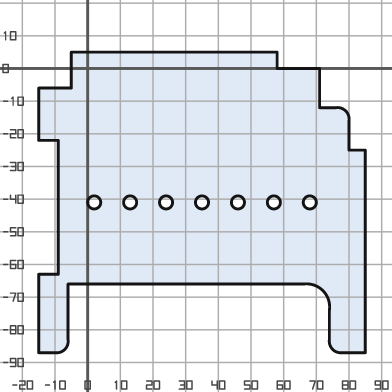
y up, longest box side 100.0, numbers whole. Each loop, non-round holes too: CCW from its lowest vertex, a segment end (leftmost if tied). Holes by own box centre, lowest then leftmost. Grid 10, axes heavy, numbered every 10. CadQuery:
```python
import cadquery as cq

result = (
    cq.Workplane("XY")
    .moveTo(-15.0, -87.0)
    .lineTo(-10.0, -87.0)
    .threePointArc((-7.0, -86.0), (-6.0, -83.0))
    .lineTo(-6.0, -66.0)
    .lineTo(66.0, -66.0)
    .threePointArc((72.0, -68.0), (74.0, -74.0))
    .lineTo(74.0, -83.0)
    .threePointArc((75.0, -86.0), (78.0, -87.0))
    .lineTo(85.0, -87.0)
    .lineTo(85.0, -25.0)
    .lineTo(80.0, -25.0)
    .lineTo(80.0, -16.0)
    .threePointArc((79.0, -13.0), (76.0, -12.0))
    .lineTo(71.0, -12.0)
    .lineTo(71.0, 0.0)
    .lineTo(58.0, 0.0)
    .lineTo(58.0, 5.0)
    .lineTo(-5.0, 5.0)
    .lineTo(-5.0, -6.0)
    .lineTo(-15.0, -6.0)
    .lineTo(-15.0, -22.0)
    .lineTo(-9.0, -22.0)
    .lineTo(-9.0, -63.0)
    .lineTo(-15.0, -63.0)
    .close()
    .moveTo(2.0, -41.0)
    .circle(2.0)
    .moveTo(13.0, -41.0)
    .circle(2.0)
    .moveTo(24.0, -41.0)
    .circle(2.0)
    .moveTo(35.0, -41.0)
    .circle(2.0)
    .moveTo(46.0, -41.0)
    .circle(2.0)
    .moveTo(57.0, -41.0)
    .circle(2.0)
    .moveTo(68.0, -41.0)
    .circle(2.0)
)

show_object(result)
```